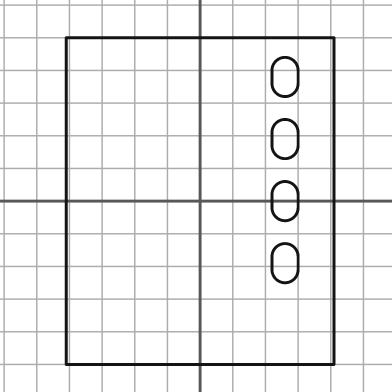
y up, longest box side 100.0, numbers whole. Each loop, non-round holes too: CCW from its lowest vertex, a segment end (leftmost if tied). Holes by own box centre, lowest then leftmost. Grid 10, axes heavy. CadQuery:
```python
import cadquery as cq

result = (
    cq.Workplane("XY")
    .moveTo(-41.0, -50.0)
    .lineTo(41.0, -50.0)
    .lineTo(41.0, 50.0)
    .lineTo(-41.0, 50.0)
    .close()
    .moveTo(22.0, -21.0)
    .threePointArc((26.0, -25.0), (30.0, -21.0))
    .lineTo(30.0, -17.0)
    .threePointArc((26.0, -13.0), (22.0, -17.0))
    .close()
    .moveTo(22.0, -2.0)
    .threePointArc((26.0, -6.0), (30.0, -2.0))
    .lineTo(30.0, 2.0)
    .threePointArc((26.0, 6.0), (22.0, 2.0))
    .close()
    .moveTo(22.0, 17.0)
    .threePointArc((26.0, 13.0), (30.0, 17.0))
    .lineTo(30.0, 21.0)
    .threePointArc((26.0, 25.0), (22.0, 21.0))
    .close()
    .moveTo(22.0, 36.0)
    .threePointArc((26.0, 32.0), (30.0, 36.0))
    .lineTo(30.0, 40.0)
    .threePointArc((26.0, 44.0), (22.0, 40.0))
    .close()
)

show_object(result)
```